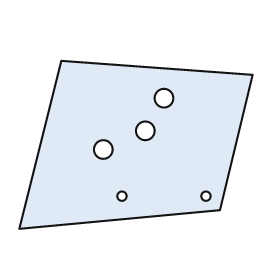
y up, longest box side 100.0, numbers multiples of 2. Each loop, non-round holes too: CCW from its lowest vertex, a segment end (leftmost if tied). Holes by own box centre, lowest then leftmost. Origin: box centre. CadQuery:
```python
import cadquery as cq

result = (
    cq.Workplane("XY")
    .moveTo(-50.0, -36.0)
    .lineTo(36.0, -28.0)
    .lineTo(50.0, 30.0)
    .lineTo(-32.0, 36.0)
    .close()
    .moveTo(-6.0, -22.0)
    .circle(2.0)
    .moveTo(30.0, -22.0)
    .circle(2.0)
    .moveTo(-14.0, -2.0)
    .circle(4.0)
    .moveTo(4.0, 6.0)
    .circle(4.0)
    .moveTo(12.0, 20.0)
    .circle(4.0)
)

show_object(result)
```